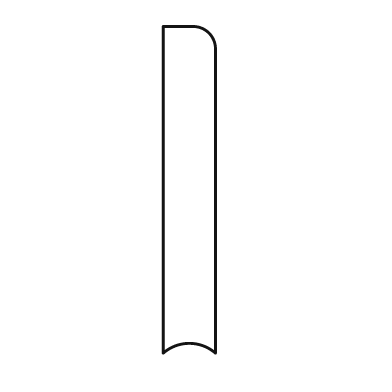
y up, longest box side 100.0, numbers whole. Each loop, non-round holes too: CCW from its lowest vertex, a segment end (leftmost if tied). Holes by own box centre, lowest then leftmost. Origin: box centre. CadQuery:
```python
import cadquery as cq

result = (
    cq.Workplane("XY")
    .moveTo(-8.0, -50.0)
    .threePointArc((0.0, -47.0), (8.0, -50.0))
    .lineTo(8.0, 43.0)
    .threePointArc((6.0, 48.0), (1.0, 50.0))
    .lineTo(-8.0, 50.0)
    .close()
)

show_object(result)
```